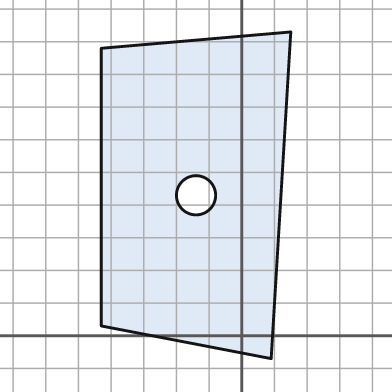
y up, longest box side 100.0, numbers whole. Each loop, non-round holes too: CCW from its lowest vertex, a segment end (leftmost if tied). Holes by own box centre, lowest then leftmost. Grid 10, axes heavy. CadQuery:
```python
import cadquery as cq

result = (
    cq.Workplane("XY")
    .moveTo(9.0, -7.0)
    .lineTo(15.0, 93.0)
    .lineTo(-43.0, 88.0)
    .lineTo(-43.0, 3.0)
    .close()
    .moveTo(-14.0, 43.0)
    .circle(6.0)
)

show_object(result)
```